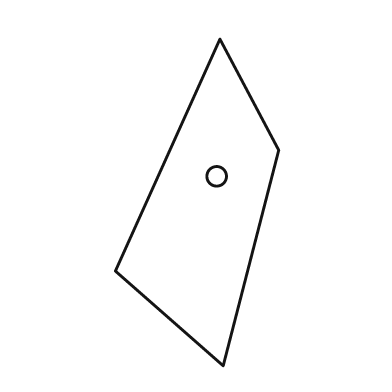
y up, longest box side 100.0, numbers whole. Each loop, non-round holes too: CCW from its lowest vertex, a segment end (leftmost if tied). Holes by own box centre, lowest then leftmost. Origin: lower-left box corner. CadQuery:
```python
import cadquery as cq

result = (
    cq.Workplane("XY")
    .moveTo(33.0, 0.0)
    .lineTo(50.0, 66.0)
    .lineTo(32.0, 100.0)
    .lineTo(0.0, 29.0)
    .close()
    .moveTo(31.0, 58.0)
    .circle(3.0)
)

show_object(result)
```